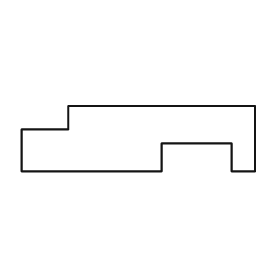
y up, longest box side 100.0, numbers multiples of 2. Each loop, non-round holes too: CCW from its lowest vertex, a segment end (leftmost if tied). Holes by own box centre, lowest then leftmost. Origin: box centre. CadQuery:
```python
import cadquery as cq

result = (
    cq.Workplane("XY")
    .moveTo(-50.0, -14.0)
    .lineTo(10.0, -14.0)
    .lineTo(10.0, -2.0)
    .lineTo(40.0, -2.0)
    .lineTo(40.0, -14.0)
    .lineTo(50.0, -14.0)
    .lineTo(50.0, 14.0)
    .lineTo(-30.0, 14.0)
    .lineTo(-30.0, 4.0)
    .lineTo(-50.0, 4.0)
    .close()
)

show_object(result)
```